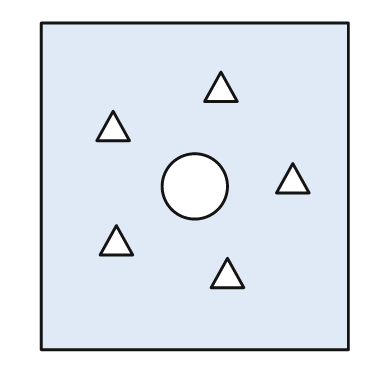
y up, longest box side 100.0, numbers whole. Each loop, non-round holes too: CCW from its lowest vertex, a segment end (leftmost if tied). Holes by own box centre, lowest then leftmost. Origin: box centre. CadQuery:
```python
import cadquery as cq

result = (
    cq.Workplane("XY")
    .moveTo(-47.0, -50.0)
    .lineTo(47.0, -50.0)
    .lineTo(47.0, 50.0)
    .lineTo(-47.0, 50.0)
    .close()
    .moveTo(5.0, -31.0)
    .lineTo(15.0, -31.0)
    .lineTo(10.0, -22.0)
    .close()
    .moveTo(-29.0, -21.0)
    .lineTo(-19.0, -21.0)
    .lineTo(-24.0, -12.0)
    .close()
    .moveTo(0.0, 0.0)
    .circle(10.0)
    .moveTo(25.0, -2.0)
    .lineTo(35.0, -2.0)
    .lineTo(30.0, 7.0)
    .close()
    .moveTo(-30.0, 14.0)
    .lineTo(-20.0, 14.0)
    .lineTo(-25.0, 23.0)
    .close()
    .moveTo(3.0, 26.0)
    .lineTo(13.0, 26.0)
    .lineTo(8.0, 35.0)
    .close()
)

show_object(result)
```